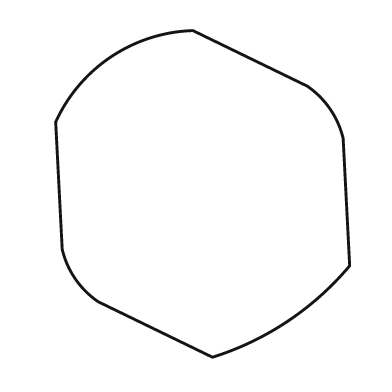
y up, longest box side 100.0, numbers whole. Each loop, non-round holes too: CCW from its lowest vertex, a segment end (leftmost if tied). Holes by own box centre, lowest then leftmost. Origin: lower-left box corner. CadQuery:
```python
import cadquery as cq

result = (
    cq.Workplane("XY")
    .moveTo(48.0, 0.0)
    .threePointArc((71.0, 11.0), (90.0, 28.0))
    .lineTo(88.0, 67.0)
    .threePointArc((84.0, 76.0), (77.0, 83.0))
    .lineTo(42.0, 100.0)
    .threePointArc((17.0, 92.0), (0.0, 72.0))
    .lineTo(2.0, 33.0)
    .threePointArc((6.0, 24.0), (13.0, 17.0))
    .close()
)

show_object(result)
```